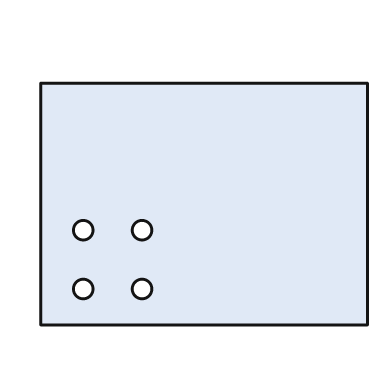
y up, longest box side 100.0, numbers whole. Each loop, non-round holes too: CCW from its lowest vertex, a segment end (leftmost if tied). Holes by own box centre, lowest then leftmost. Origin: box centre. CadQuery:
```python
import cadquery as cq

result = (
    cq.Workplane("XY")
    .moveTo(-50.0, -37.0)
    .lineTo(50.0, -37.0)
    .lineTo(50.0, 37.0)
    .lineTo(-50.0, 37.0)
    .close()
    .moveTo(-37.0, -26.0)
    .circle(3.0)
    .moveTo(-19.0, -26.0)
    .circle(3.0)
    .moveTo(-37.0, -8.0)
    .circle(3.0)
    .moveTo(-19.0, -8.0)
    .circle(3.0)
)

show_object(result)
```